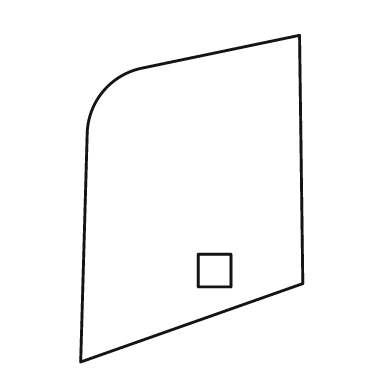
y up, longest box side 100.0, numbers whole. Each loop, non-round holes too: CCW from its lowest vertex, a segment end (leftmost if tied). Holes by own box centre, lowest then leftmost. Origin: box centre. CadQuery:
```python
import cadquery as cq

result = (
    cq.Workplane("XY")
    .moveTo(-34.0, -50.0)
    .lineTo(34.0, -26.0)
    .lineTo(33.0, 50.0)
    .lineTo(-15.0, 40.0)
    .threePointArc((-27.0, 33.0), (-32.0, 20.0))
    .close()
    .moveTo(2.0, -27.0)
    .lineTo(12.0, -27.0)
    .lineTo(12.0, -17.0)
    .lineTo(2.0, -17.0)
    .close()
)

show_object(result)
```